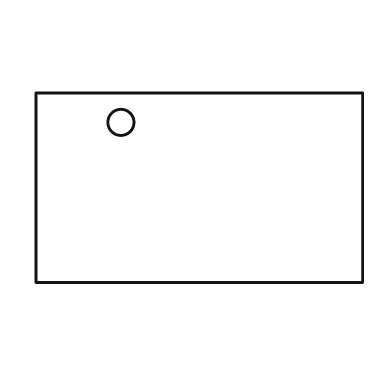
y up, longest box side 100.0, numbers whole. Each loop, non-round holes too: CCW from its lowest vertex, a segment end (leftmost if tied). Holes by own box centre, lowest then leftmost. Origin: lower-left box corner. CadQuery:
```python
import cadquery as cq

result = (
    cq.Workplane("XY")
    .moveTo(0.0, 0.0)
    .lineTo(100.0, 0.0)
    .lineTo(100.0, 58.0)
    .lineTo(0.0, 58.0)
    .close()
    .moveTo(26.0, 49.0)
    .circle(4.0)
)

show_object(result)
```